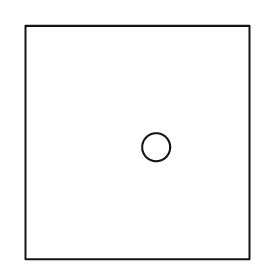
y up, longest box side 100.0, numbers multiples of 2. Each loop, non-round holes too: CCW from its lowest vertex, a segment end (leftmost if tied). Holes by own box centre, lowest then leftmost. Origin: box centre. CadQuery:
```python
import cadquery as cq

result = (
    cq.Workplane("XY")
    .moveTo(-48.0, -50.0)
    .lineTo(48.0, -50.0)
    .lineTo(48.0, 50.0)
    .lineTo(-48.0, 50.0)
    .close()
    .moveTo(8.0, -2.0)
    .circle(6.0)
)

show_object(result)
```